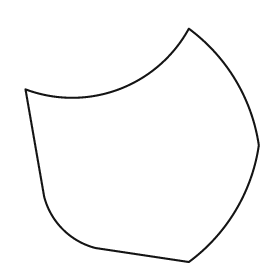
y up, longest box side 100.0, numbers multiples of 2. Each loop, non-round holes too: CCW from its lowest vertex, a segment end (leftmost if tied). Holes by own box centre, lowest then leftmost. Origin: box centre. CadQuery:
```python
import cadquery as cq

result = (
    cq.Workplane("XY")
    .moveTo(20.0, -50.0)
    .threePointArc((40.0, -28.0), (50.0, 0.0))
    .threePointArc((40.0, 28.0), (20.0, 50.0))
    .threePointArc((-10.0, 24.0), (-50.0, 24.0))
    .lineTo(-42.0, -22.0)
    .threePointArc((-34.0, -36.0), (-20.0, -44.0))
    .close()
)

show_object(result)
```